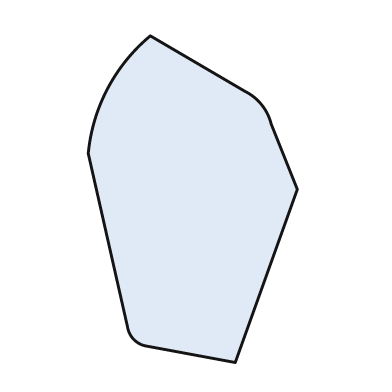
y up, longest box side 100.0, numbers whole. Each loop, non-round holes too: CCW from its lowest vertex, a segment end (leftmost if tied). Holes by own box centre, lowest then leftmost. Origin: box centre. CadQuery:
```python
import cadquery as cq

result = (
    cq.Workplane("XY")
    .moveTo(13.0, -50.0)
    .lineTo(32.0, 3.0)
    .lineTo(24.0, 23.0)
    .threePointArc((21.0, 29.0), (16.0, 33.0))
    .lineTo(-13.0, 50.0)
    .threePointArc((-26.0, 34.0), (-32.0, 14.0))
    .lineTo(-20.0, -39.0)
    .threePointArc((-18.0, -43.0), (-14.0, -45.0))
    .close()
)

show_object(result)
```